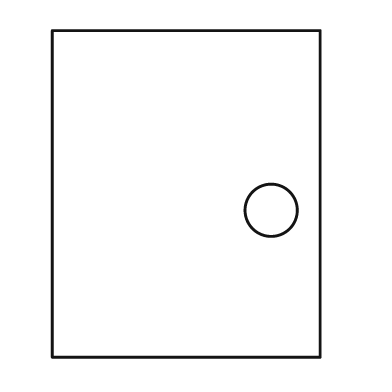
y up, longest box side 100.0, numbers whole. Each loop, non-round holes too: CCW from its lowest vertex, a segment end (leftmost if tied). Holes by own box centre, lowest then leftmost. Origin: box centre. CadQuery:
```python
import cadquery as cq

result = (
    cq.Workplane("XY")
    .moveTo(-41.0, -50.0)
    .lineTo(41.0, -50.0)
    .lineTo(41.0, 50.0)
    .lineTo(-41.0, 50.0)
    .close()
    .moveTo(26.0, -5.0)
    .circle(8.0)
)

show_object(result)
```